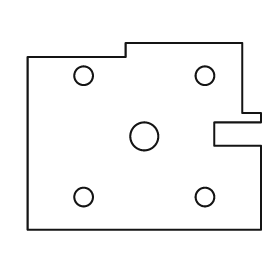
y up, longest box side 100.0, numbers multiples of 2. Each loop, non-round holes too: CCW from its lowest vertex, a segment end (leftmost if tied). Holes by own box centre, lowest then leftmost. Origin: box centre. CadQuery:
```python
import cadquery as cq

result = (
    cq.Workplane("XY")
    .moveTo(-50.0, -40.0)
    .lineTo(50.0, -40.0)
    .lineTo(50.0, -4.0)
    .lineTo(30.0, -4.0)
    .lineTo(30.0, 6.0)
    .lineTo(50.0, 6.0)
    .lineTo(50.0, 10.0)
    .lineTo(42.0, 10.0)
    .lineTo(42.0, 40.0)
    .lineTo(-8.0, 40.0)
    .lineTo(-8.0, 34.0)
    .lineTo(-50.0, 34.0)
    .close()
    .moveTo(-26.0, -26.0)
    .circle(4.0)
    .moveTo(26.0, -26.0)
    .circle(4.0)
    .moveTo(0.0, 0.0)
    .circle(6.0)
    .moveTo(-26.0, 26.0)
    .circle(4.0)
    .moveTo(26.0, 26.0)
    .circle(4.0)
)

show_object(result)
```